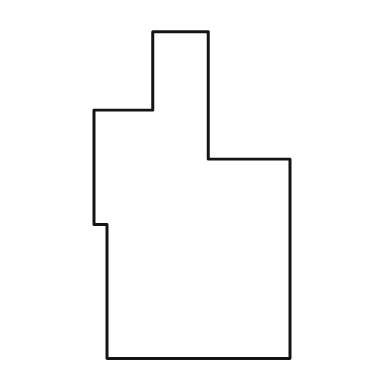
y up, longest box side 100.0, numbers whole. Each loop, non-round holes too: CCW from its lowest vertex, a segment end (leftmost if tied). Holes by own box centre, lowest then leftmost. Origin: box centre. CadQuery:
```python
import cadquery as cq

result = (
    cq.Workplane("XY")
    .moveTo(-26.0, -50.0)
    .lineTo(30.0, -50.0)
    .lineTo(30.0, 11.0)
    .lineTo(5.0, 11.0)
    .lineTo(5.0, 50.0)
    .lineTo(-12.0, 50.0)
    .lineTo(-12.0, 26.0)
    .lineTo(-30.0, 26.0)
    .lineTo(-30.0, -9.0)
    .lineTo(-26.0, -9.0)
    .close()
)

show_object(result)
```